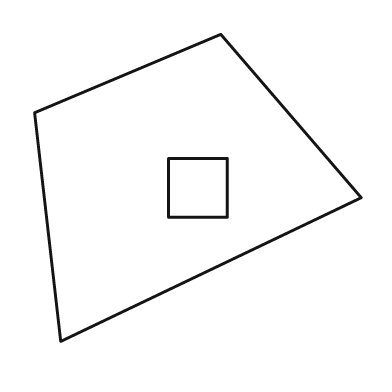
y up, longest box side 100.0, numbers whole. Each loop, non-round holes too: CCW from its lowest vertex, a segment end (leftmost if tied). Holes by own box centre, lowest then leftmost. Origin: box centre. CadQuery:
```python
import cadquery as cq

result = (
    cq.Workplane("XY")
    .moveTo(-42.0, -47.0)
    .lineTo(50.0, -3.0)
    .lineTo(7.0, 47.0)
    .lineTo(-50.0, 23.0)
    .close()
    .moveTo(-9.0, -9.0)
    .lineTo(9.0, -9.0)
    .lineTo(9.0, 9.0)
    .lineTo(-9.0, 9.0)
    .close()
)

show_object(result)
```